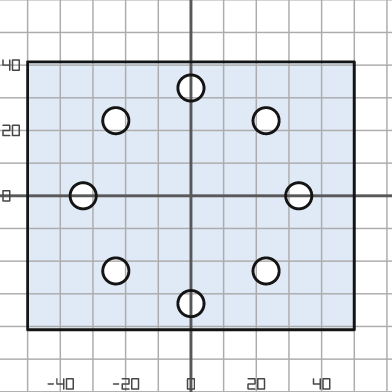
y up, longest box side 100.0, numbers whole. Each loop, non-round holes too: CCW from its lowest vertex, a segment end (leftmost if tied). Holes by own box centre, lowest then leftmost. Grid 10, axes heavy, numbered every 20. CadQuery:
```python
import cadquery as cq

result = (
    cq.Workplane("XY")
    .moveTo(-50.0, -41.0)
    .lineTo(50.0, -41.0)
    .lineTo(50.0, 41.0)
    .lineTo(-50.0, 41.0)
    .close()
    .moveTo(0.0, -33.0)
    .circle(4.0)
    .moveTo(-23.0, -23.0)
    .circle(4.0)
    .moveTo(23.0, -23.0)
    .circle(4.0)
    .moveTo(-33.0, 0.0)
    .circle(4.0)
    .moveTo(33.0, 0.0)
    .circle(4.0)
    .moveTo(-23.0, 23.0)
    .circle(4.0)
    .moveTo(23.0, 23.0)
    .circle(4.0)
    .moveTo(0.0, 33.0)
    .circle(4.0)
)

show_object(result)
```